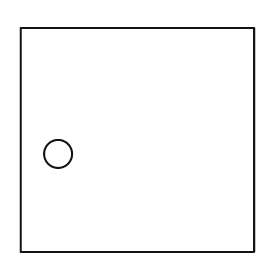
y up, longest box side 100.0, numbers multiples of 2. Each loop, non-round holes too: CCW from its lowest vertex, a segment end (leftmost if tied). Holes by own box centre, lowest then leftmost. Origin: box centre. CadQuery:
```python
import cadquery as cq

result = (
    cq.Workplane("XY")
    .moveTo(-50.0, -48.0)
    .lineTo(50.0, -48.0)
    .lineTo(50.0, 48.0)
    .lineTo(-50.0, 48.0)
    .close()
    .moveTo(-34.0, -6.0)
    .circle(6.0)
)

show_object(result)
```